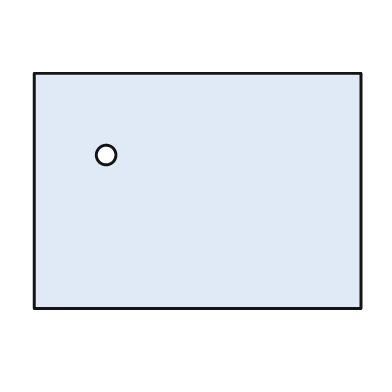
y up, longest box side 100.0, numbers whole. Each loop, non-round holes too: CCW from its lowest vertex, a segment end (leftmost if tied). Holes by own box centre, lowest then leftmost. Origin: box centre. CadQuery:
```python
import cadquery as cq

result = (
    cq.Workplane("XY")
    .moveTo(-50.0, -36.0)
    .lineTo(50.0, -36.0)
    .lineTo(50.0, 36.0)
    .lineTo(-50.0, 36.0)
    .close()
    .moveTo(-28.0, 11.0)
    .circle(3.0)
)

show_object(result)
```